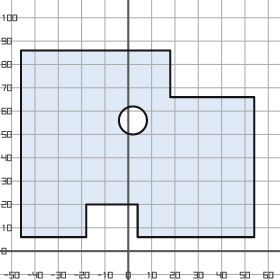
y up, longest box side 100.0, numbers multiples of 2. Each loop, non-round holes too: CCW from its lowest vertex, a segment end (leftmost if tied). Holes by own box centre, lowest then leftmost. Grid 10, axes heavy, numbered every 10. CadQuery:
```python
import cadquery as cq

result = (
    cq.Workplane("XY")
    .moveTo(-46.0, 6.0)
    .lineTo(-18.0, 6.0)
    .lineTo(-18.0, 20.0)
    .lineTo(4.0, 20.0)
    .lineTo(4.0, 6.0)
    .lineTo(54.0, 6.0)
    .lineTo(54.0, 66.0)
    .lineTo(18.0, 66.0)
    .lineTo(18.0, 86.0)
    .lineTo(-46.0, 86.0)
    .close()
    .moveTo(2.0, 56.0)
    .circle(6.0)
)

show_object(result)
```